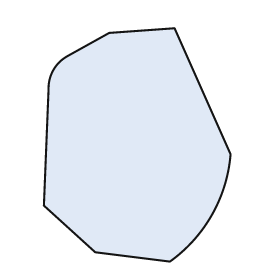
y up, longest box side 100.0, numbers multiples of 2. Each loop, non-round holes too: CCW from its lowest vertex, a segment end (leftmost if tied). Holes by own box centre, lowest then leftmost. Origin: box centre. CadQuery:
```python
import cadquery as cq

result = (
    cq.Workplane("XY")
    .moveTo(14.0, -50.0)
    .threePointArc((32.0, -30.0), (40.0, -4.0))
    .lineTo(16.0, 50.0)
    .lineTo(-12.0, 48.0)
    .lineTo(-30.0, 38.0)
    .threePointArc((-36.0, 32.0), (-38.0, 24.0))
    .lineTo(-40.0, -26.0)
    .lineTo(-18.0, -46.0)
    .close()
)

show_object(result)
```